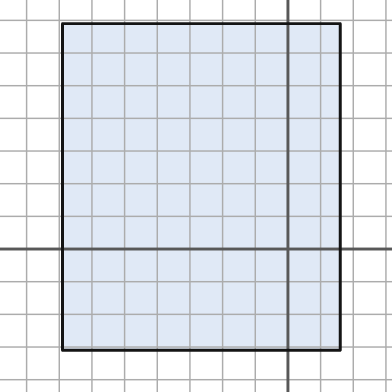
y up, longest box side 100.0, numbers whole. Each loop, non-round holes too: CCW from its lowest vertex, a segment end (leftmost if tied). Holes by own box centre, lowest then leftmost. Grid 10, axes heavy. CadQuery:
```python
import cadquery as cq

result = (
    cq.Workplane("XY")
    .moveTo(-69.0, -31.0)
    .lineTo(16.0, -31.0)
    .lineTo(16.0, 69.0)
    .lineTo(-69.0, 69.0)
    .close()
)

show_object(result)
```